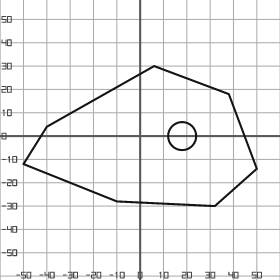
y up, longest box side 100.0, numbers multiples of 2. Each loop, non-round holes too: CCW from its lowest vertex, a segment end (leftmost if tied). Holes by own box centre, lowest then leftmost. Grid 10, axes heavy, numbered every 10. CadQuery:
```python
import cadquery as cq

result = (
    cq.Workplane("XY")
    .moveTo(32.0, -30.0)
    .lineTo(50.0, -14.0)
    .lineTo(38.0, 18.0)
    .lineTo(6.0, 30.0)
    .lineTo(-40.0, 4.0)
    .lineTo(-50.0, -12.0)
    .lineTo(-10.0, -28.0)
    .close()
    .moveTo(18.0, 0.0)
    .circle(6.0)
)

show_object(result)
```